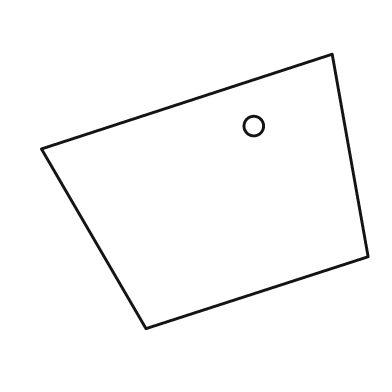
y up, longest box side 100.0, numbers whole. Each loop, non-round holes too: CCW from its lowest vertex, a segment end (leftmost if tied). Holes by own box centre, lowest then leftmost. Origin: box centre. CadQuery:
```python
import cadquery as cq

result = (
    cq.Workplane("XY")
    .moveTo(-18.0, -42.0)
    .lineTo(50.0, -20.0)
    .lineTo(39.0, 42.0)
    .lineTo(-50.0, 13.0)
    .close()
    .moveTo(15.0, 20.0)
    .circle(3.0)
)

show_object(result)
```